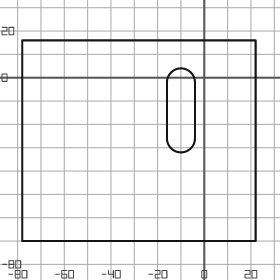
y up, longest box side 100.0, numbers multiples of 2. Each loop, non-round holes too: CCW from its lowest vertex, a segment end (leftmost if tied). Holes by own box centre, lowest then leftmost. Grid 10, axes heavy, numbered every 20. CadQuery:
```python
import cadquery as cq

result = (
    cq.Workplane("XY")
    .moveTo(-78.0, -70.0)
    .lineTo(22.0, -70.0)
    .lineTo(22.0, 16.0)
    .lineTo(-78.0, 16.0)
    .close()
    .moveTo(-16.0, -26.0)
    .threePointArc((-10.0, -32.0), (-4.0, -26.0))
    .lineTo(-4.0, -2.0)
    .threePointArc((-10.0, 4.0), (-16.0, -2.0))
    .close()
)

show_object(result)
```